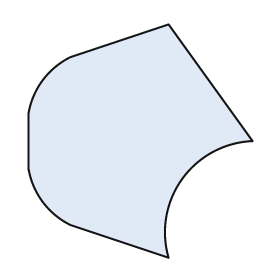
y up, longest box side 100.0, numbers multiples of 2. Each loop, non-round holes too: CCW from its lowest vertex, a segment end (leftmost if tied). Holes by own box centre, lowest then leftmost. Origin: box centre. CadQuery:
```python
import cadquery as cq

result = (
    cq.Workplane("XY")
    .moveTo(12.0, -50.0)
    .threePointArc((18.0, -16.0), (48.0, 0.0))
    .lineTo(12.0, 50.0)
    .lineTo(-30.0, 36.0)
    .threePointArc((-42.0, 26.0), (-48.0, 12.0))
    .lineTo(-48.0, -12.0)
    .threePointArc((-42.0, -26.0), (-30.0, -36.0))
    .close()
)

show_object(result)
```